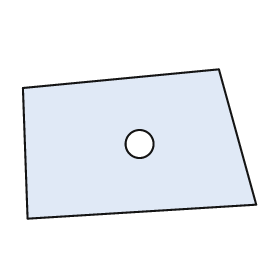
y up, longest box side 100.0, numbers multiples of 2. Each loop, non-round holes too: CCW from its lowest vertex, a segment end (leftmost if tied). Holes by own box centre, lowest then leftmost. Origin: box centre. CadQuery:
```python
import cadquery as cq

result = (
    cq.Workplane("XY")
    .moveTo(-48.0, -32.0)
    .lineTo(50.0, -26.0)
    .lineTo(34.0, 32.0)
    .lineTo(-50.0, 24.0)
    .close()
    .moveTo(0.0, 0.0)
    .circle(6.0)
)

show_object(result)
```